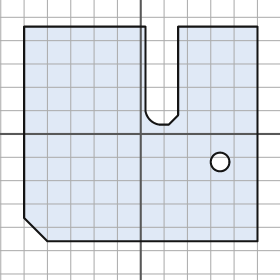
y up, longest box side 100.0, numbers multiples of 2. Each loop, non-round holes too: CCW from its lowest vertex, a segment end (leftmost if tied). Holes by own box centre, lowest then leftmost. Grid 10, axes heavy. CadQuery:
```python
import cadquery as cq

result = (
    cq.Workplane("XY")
    .moveTo(-40.0, -46.0)
    .lineTo(50.0, -46.0)
    .lineTo(50.0, 46.0)
    .lineTo(16.0, 46.0)
    .lineTo(16.0, 8.0)
    .lineTo(12.0, 4.0)
    .lineTo(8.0, 4.0)
    .threePointArc((4.0, 6.0), (2.0, 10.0))
    .lineTo(2.0, 46.0)
    .lineTo(-50.0, 46.0)
    .lineTo(-50.0, -36.0)
    .close()
    .moveTo(34.0, -12.0)
    .circle(4.0)
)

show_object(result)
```